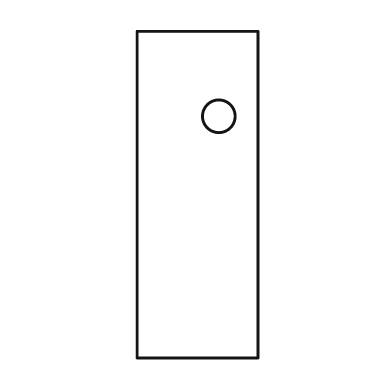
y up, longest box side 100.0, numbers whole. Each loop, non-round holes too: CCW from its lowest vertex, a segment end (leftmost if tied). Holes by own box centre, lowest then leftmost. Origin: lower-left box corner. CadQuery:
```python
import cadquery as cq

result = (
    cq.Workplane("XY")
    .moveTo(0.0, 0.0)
    .lineTo(37.0, 0.0)
    .lineTo(37.0, 100.0)
    .lineTo(0.0, 100.0)
    .close()
    .moveTo(25.0, 74.0)
    .circle(5.0)
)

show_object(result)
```